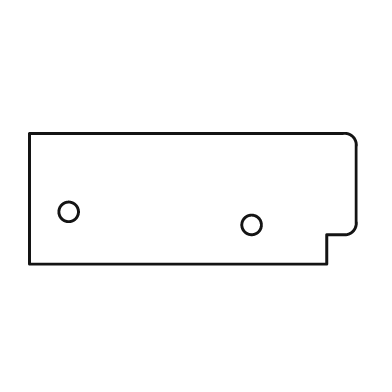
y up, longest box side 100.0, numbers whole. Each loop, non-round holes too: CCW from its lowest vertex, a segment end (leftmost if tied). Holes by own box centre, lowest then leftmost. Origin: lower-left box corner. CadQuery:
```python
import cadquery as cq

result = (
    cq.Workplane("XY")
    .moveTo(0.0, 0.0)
    .lineTo(91.0, 0.0)
    .lineTo(91.0, 9.0)
    .lineTo(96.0, 9.0)
    .threePointArc((99.0, 10.0), (100.0, 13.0))
    .lineTo(100.0, 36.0)
    .threePointArc((99.0, 39.0), (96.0, 40.0))
    .lineTo(0.0, 40.0)
    .close()
    .moveTo(68.0, 12.0)
    .circle(3.0)
    .moveTo(12.0, 16.0)
    .circle(3.0)
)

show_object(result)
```